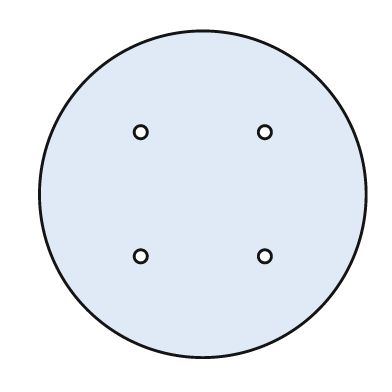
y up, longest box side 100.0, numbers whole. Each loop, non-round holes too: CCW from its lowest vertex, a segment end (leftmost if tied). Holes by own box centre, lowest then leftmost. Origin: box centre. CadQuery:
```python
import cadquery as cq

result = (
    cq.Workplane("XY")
    .moveTo(0.0, 0.0)
    .circle(50.0)
    .moveTo(-19.0, -19.0)
    .circle(2.0)
    .moveTo(19.0, -19.0)
    .circle(2.0)
    .moveTo(-19.0, 19.0)
    .circle(2.0)
    .moveTo(19.0, 19.0)
    .circle(2.0)
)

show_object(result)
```